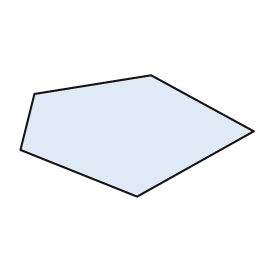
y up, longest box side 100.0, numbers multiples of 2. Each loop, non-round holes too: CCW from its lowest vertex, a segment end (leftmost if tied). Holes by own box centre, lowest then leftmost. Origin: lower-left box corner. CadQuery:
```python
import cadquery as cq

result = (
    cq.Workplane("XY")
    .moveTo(50.0, 0.0)
    .lineTo(100.0, 28.0)
    .lineTo(56.0, 52.0)
    .lineTo(6.0, 44.0)
    .lineTo(0.0, 20.0)
    .close()
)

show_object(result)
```